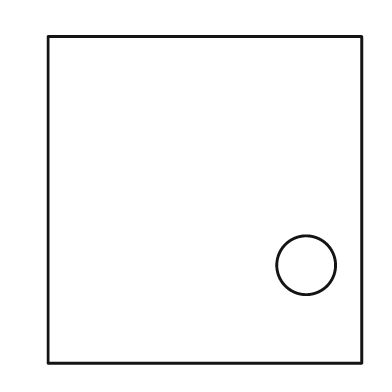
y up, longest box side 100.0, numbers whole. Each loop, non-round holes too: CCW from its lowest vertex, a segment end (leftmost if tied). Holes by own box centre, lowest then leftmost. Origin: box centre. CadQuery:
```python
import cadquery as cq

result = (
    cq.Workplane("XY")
    .moveTo(-48.0, -50.0)
    .lineTo(48.0, -50.0)
    .lineTo(48.0, 50.0)
    .lineTo(-48.0, 50.0)
    .close()
    .moveTo(31.0, -20.0)
    .circle(9.0)
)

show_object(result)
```